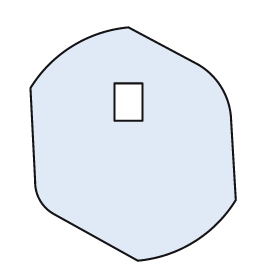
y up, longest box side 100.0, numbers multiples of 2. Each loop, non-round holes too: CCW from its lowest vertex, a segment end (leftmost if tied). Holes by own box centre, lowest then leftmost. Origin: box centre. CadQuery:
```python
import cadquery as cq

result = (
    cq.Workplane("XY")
    .moveTo(2.0, -50.0)
    .threePointArc((26.0, -42.0), (44.0, -24.0))
    .lineTo(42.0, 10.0)
    .threePointArc((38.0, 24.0), (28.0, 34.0))
    .lineTo(-2.0, 50.0)
    .threePointArc((-26.0, 42.0), (-44.0, 24.0))
    .lineTo(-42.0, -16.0)
    .threePointArc((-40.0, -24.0), (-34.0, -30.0))
    .close()
    .moveTo(-8.0, 10.0)
    .lineTo(4.0, 10.0)
    .lineTo(4.0, 26.0)
    .lineTo(-8.0, 26.0)
    .close()
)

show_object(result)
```